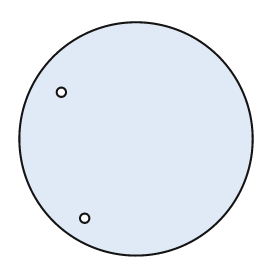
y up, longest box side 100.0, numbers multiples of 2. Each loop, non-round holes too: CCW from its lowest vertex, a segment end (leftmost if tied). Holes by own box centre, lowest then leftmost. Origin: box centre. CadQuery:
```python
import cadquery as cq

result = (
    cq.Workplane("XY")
    .moveTo(0.0, 0.0)
    .circle(50.0)
    .moveTo(-22.0, -34.0)
    .circle(2.0)
    .moveTo(-32.0, 20.0)
    .circle(2.0)
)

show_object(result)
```